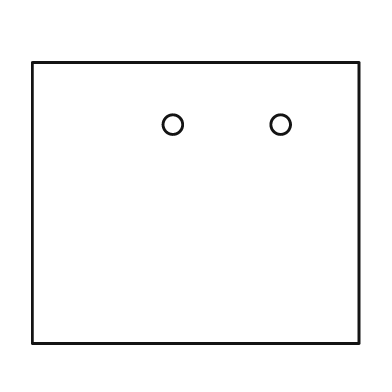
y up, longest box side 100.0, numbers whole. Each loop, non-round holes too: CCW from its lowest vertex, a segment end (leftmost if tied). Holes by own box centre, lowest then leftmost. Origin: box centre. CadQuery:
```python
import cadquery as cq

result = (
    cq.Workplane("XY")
    .moveTo(-50.0, -43.0)
    .lineTo(50.0, -43.0)
    .lineTo(50.0, 43.0)
    .lineTo(-50.0, 43.0)
    .close()
    .moveTo(-7.0, 24.0)
    .circle(3.0)
    .moveTo(26.0, 24.0)
    .circle(3.0)
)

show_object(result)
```